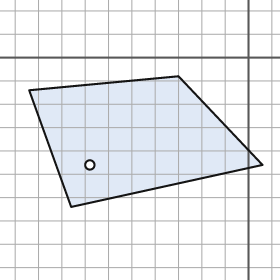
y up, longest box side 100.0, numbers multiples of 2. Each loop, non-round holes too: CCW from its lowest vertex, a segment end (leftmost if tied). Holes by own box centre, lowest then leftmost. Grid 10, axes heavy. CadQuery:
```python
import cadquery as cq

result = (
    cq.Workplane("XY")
    .moveTo(-76.0, -64.0)
    .lineTo(6.0, -46.0)
    .lineTo(-30.0, -8.0)
    .lineTo(-94.0, -14.0)
    .close()
    .moveTo(-68.0, -46.0)
    .circle(2.0)
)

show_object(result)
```